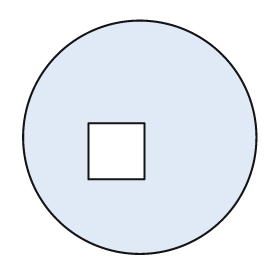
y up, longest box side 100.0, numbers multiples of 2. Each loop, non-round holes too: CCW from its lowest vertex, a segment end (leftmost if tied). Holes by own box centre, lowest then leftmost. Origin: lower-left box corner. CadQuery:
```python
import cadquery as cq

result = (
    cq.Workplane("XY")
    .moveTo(50.0, 50.0)
    .circle(50.0)
    .moveTo(28.0, 32.0)
    .lineTo(52.0, 32.0)
    .lineTo(52.0, 56.0)
    .lineTo(28.0, 56.0)
    .close()
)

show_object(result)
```